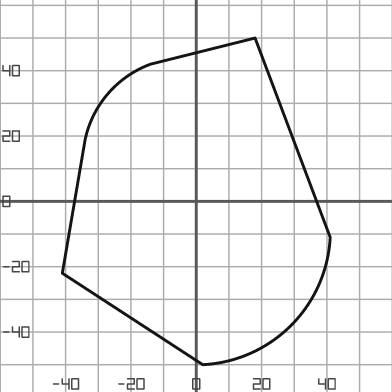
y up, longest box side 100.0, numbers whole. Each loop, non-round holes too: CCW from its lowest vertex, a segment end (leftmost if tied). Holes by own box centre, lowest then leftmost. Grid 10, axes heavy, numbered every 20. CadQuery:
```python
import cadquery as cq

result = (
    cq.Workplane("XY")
    .moveTo(2.0, -50.0)
    .threePointArc((29.0, -38.0), (41.0, -11.0))
    .lineTo(18.0, 50.0)
    .lineTo(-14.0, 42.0)
    .threePointArc((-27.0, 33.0), (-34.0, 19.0))
    .lineTo(-41.0, -22.0)
    .close()
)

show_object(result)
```